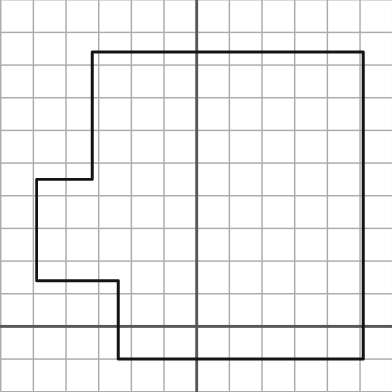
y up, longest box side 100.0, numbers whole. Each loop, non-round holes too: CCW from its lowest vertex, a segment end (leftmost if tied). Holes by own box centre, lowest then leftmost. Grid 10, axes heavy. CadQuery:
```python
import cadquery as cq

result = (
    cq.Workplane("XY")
    .moveTo(-24.0, -10.0)
    .lineTo(51.0, -10.0)
    .lineTo(51.0, 84.0)
    .lineTo(-32.0, 84.0)
    .lineTo(-32.0, 45.0)
    .lineTo(-49.0, 45.0)
    .lineTo(-49.0, 14.0)
    .lineTo(-24.0, 14.0)
    .close()
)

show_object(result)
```